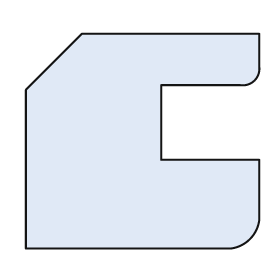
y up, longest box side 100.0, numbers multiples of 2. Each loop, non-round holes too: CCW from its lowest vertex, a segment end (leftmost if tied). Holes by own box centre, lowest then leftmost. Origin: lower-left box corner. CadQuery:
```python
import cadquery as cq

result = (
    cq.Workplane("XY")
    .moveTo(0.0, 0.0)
    .lineTo(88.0, 0.0)
    .threePointArc((96.0, 4.0), (100.0, 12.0))
    .lineTo(100.0, 38.0)
    .lineTo(58.0, 38.0)
    .lineTo(58.0, 70.0)
    .lineTo(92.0, 70.0)
    .threePointArc((98.0, 72.0), (100.0, 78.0))
    .lineTo(100.0, 92.0)
    .lineTo(24.0, 92.0)
    .lineTo(0.0, 68.0)
    .close()
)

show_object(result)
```